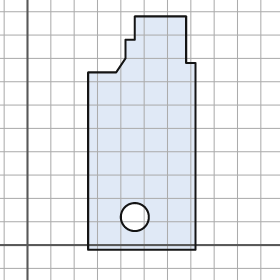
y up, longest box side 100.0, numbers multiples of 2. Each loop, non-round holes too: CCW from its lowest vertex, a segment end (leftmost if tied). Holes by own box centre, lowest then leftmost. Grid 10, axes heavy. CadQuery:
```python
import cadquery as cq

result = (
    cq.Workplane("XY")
    .moveTo(26.0, -2.0)
    .lineTo(72.0, -2.0)
    .lineTo(72.0, 78.0)
    .lineTo(68.0, 78.0)
    .lineTo(68.0, 98.0)
    .lineTo(46.0, 98.0)
    .lineTo(46.0, 88.0)
    .lineTo(42.0, 88.0)
    .lineTo(42.0, 80.0)
    .lineTo(38.0, 74.0)
    .lineTo(26.0, 74.0)
    .close()
    .moveTo(46.0, 12.0)
    .circle(6.0)
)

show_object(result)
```